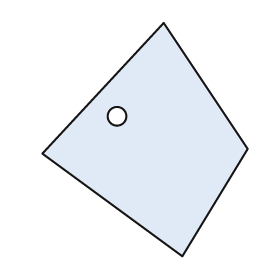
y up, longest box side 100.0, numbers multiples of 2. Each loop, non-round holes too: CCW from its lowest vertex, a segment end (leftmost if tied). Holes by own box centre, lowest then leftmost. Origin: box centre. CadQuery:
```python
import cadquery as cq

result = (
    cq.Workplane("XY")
    .moveTo(16.0, -50.0)
    .lineTo(44.0, -4.0)
    .lineTo(8.0, 50.0)
    .lineTo(-44.0, -6.0)
    .close()
    .moveTo(-12.0, 10.0)
    .circle(4.0)
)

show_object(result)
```